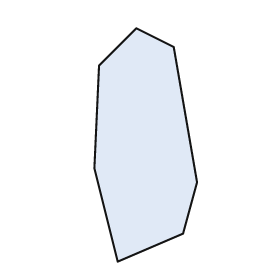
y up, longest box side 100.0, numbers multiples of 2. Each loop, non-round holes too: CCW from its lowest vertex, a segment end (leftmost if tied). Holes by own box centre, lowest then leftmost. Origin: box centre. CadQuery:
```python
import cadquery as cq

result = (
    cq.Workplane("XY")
    .moveTo(-12.0, -50.0)
    .lineTo(16.0, -38.0)
    .lineTo(22.0, -16.0)
    .lineTo(12.0, 42.0)
    .lineTo(-4.0, 50.0)
    .lineTo(-20.0, 34.0)
    .lineTo(-22.0, -10.0)
    .close()
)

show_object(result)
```